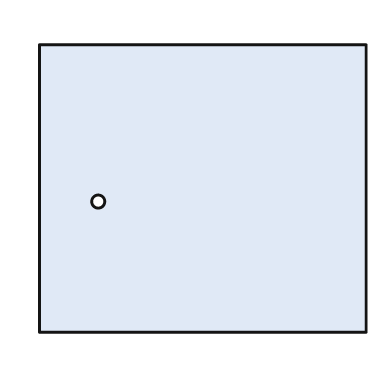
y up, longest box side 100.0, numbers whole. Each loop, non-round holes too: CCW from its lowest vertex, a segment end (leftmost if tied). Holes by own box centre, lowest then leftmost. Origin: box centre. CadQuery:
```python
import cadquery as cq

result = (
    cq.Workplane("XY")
    .moveTo(-50.0, -44.0)
    .lineTo(50.0, -44.0)
    .lineTo(50.0, 44.0)
    .lineTo(-50.0, 44.0)
    .close()
    .moveTo(-32.0, -4.0)
    .circle(2.0)
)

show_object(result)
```